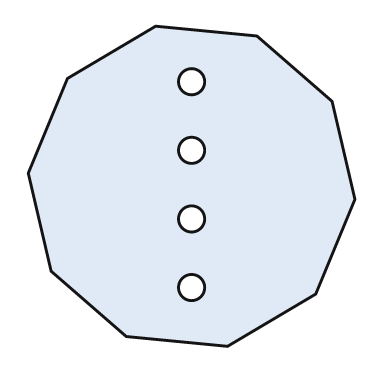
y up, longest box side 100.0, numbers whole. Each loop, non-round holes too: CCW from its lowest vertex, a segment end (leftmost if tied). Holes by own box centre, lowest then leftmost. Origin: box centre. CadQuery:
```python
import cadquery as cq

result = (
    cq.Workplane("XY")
    .moveTo(11.0, -49.0)
    .lineTo(38.0, -33.0)
    .lineTo(50.0, -4.0)
    .lineTo(43.0, 26.0)
    .lineTo(20.0, 46.0)
    .lineTo(-11.0, 49.0)
    .lineTo(-38.0, 33.0)
    .lineTo(-50.0, 4.0)
    .lineTo(-43.0, -26.0)
    .lineTo(-20.0, -46.0)
    .close()
    .moveTo(0.0, -31.0)
    .circle(4.0)
    .moveTo(0.0, -10.0)
    .circle(4.0)
    .moveTo(0.0, 11.0)
    .circle(4.0)
    .moveTo(0.0, 32.0)
    .circle(4.0)
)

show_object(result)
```